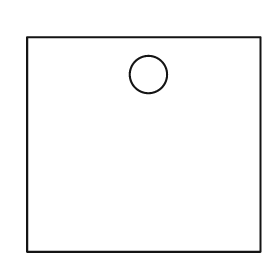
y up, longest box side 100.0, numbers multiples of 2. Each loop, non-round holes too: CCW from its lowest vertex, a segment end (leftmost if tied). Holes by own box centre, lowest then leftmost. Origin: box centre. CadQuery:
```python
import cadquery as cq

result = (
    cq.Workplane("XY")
    .moveTo(-50.0, -46.0)
    .lineTo(50.0, -46.0)
    .lineTo(50.0, 46.0)
    .lineTo(-50.0, 46.0)
    .close()
    .moveTo(2.0, 30.0)
    .circle(8.0)
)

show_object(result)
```